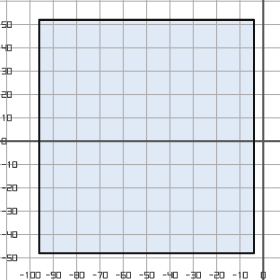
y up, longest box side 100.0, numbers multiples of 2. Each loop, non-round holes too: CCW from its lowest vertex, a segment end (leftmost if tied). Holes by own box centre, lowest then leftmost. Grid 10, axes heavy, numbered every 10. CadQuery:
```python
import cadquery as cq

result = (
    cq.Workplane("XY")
    .moveTo(-96.0, -48.0)
    .lineTo(-4.0, -48.0)
    .lineTo(-4.0, 52.0)
    .lineTo(-96.0, 52.0)
    .close()
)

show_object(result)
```